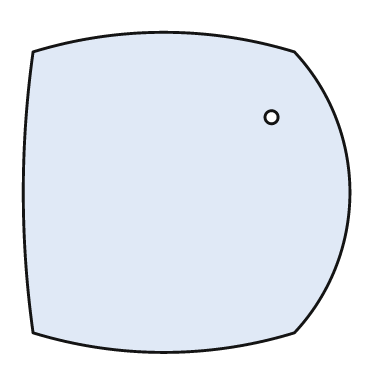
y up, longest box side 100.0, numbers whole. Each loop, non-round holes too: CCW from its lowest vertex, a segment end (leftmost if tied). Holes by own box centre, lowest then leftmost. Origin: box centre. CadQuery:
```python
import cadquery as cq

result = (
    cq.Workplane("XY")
    .moveTo(-47.0, -43.0)
    .threePointArc((-7.0, -49.0), (33.0, -43.0))
    .threePointArc((50.0, 0.0), (33.0, 43.0))
    .threePointArc((-7.0, 49.0), (-47.0, 43.0))
    .threePointArc((-50.0, 0.0), (-47.0, -43.0))
    .close()
    .moveTo(26.0, 23.0)
    .circle(2.0)
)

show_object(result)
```